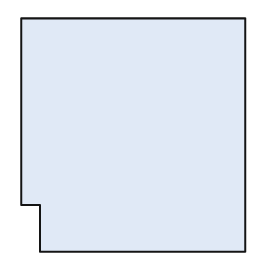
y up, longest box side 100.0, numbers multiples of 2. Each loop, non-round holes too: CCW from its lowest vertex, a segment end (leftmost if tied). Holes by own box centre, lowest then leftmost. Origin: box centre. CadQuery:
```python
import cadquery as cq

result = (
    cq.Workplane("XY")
    .moveTo(-40.0, -50.0)
    .lineTo(48.0, -50.0)
    .lineTo(48.0, 50.0)
    .lineTo(-48.0, 50.0)
    .lineTo(-48.0, -30.0)
    .lineTo(-40.0, -30.0)
    .close()
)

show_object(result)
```